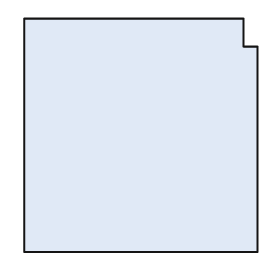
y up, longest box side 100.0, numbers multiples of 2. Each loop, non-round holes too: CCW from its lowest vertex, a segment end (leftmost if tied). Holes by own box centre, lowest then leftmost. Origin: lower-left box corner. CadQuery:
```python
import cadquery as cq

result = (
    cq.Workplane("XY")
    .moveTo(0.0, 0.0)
    .lineTo(100.0, 0.0)
    .lineTo(100.0, 88.0)
    .lineTo(94.0, 88.0)
    .lineTo(94.0, 100.0)
    .lineTo(0.0, 100.0)
    .close()
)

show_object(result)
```